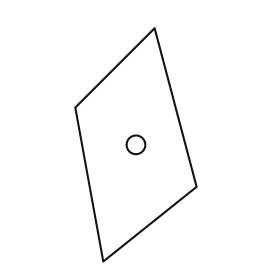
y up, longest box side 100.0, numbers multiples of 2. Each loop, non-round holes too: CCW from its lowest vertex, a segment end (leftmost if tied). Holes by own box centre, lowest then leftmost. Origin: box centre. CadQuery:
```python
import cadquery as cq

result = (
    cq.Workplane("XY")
    .moveTo(-14.0, -50.0)
    .lineTo(26.0, -18.0)
    .lineTo(8.0, 50.0)
    .lineTo(-26.0, 16.0)
    .close()
    .moveTo(0.0, 0.0)
    .circle(4.0)
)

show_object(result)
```